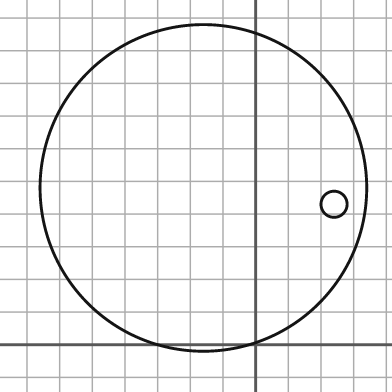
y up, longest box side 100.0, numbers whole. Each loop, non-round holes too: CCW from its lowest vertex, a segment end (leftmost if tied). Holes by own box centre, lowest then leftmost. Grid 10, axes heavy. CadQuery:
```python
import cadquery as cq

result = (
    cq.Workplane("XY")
    .moveTo(-16.0, 48.0)
    .circle(50.0)
    .moveTo(24.0, 43.0)
    .circle(4.0)
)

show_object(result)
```